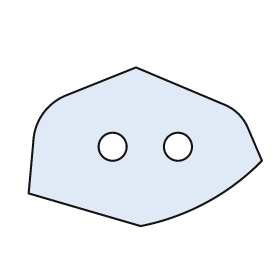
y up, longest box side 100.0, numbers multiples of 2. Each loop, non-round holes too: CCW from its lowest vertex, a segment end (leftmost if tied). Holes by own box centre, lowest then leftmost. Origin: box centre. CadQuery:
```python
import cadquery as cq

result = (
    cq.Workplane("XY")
    .moveTo(-2.0, -34.0)
    .threePointArc((26.0, -24.0), (50.0, -6.0))
    .lineTo(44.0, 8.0)
    .threePointArc((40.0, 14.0), (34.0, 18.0))
    .lineTo(-4.0, 34.0)
    .lineTo(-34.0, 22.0)
    .threePointArc((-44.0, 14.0), (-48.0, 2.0))
    .lineTo(-50.0, -20.0)
    .close()
    .moveTo(-14.0, 0.0)
    .circle(6.0)
    .moveTo(14.0, 0.0)
    .circle(6.0)
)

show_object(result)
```